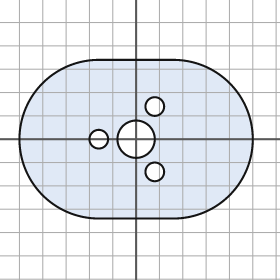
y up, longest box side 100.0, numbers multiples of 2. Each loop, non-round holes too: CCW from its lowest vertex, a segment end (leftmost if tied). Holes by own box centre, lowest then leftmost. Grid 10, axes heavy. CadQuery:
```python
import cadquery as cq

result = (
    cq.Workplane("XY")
    .moveTo(-16.0, -34.0)
    .lineTo(16.0, -34.0)
    .threePointArc((50.0, 0.0), (16.0, 34.0))
    .lineTo(-16.0, 34.0)
    .threePointArc((-50.0, 0.0), (-16.0, -34.0))
    .close()
    .moveTo(8.0, -14.0)
    .circle(4.0)
    .moveTo(-16.0, 0.0)
    .circle(4.0)
    .moveTo(0.0, 0.0)
    .circle(8.0)
    .moveTo(8.0, 14.0)
    .circle(4.0)
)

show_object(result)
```